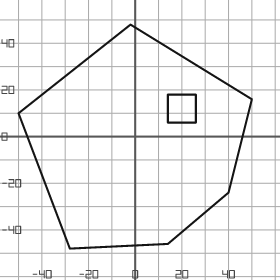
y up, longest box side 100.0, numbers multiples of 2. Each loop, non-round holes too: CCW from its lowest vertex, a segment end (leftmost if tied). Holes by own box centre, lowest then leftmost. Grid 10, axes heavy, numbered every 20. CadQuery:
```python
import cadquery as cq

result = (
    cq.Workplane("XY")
    .moveTo(-28.0, -48.0)
    .lineTo(14.0, -46.0)
    .lineTo(40.0, -24.0)
    .lineTo(50.0, 16.0)
    .lineTo(-2.0, 48.0)
    .lineTo(-50.0, 10.0)
    .close()
    .moveTo(14.0, 6.0)
    .lineTo(26.0, 6.0)
    .lineTo(26.0, 18.0)
    .lineTo(14.0, 18.0)
    .close()
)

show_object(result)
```